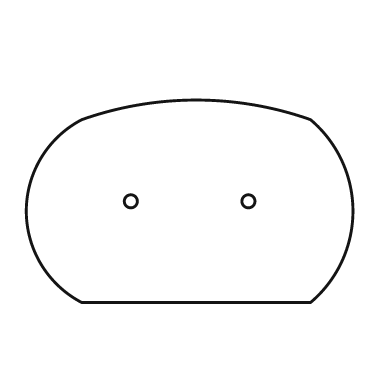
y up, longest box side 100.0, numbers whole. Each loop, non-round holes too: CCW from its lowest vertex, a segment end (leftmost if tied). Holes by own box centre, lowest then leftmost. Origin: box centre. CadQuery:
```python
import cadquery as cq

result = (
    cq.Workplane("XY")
    .moveTo(-33.0, -31.0)
    .lineTo(37.0, -31.0)
    .threePointArc((50.0, -3.0), (37.0, 25.0))
    .threePointArc((2.0, 31.0), (-33.0, 25.0))
    .threePointArc((-50.0, -3.0), (-33.0, -31.0))
    .close()
    .moveTo(-18.0, 0.0)
    .circle(2.0)
    .moveTo(18.0, 0.0)
    .circle(2.0)
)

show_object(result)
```